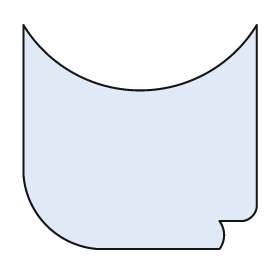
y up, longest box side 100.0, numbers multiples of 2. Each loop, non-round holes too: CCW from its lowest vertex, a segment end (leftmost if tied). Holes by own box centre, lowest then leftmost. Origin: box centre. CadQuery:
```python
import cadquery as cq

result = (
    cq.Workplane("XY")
    .moveTo(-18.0, -48.0)
    .lineTo(34.0, -48.0)
    .threePointArc((36.0, -42.0), (34.0, -36.0))
    .lineTo(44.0, -36.0)
    .threePointArc((48.0, -34.0), (50.0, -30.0))
    .lineTo(50.0, 48.0)
    .threePointArc((0.0, 20.0), (-50.0, 48.0))
    .lineTo(-50.0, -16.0)
    .threePointArc((-40.0, -38.0), (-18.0, -48.0))
    .close()
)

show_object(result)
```